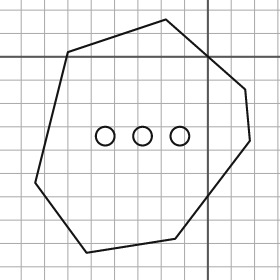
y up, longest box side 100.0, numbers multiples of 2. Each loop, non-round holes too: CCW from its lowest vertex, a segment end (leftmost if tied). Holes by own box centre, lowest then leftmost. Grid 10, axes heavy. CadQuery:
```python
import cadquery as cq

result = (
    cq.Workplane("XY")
    .moveTo(-52.0, -84.0)
    .lineTo(-14.0, -78.0)
    .lineTo(18.0, -36.0)
    .lineTo(16.0, -14.0)
    .lineTo(-18.0, 16.0)
    .lineTo(-60.0, 2.0)
    .lineTo(-74.0, -54.0)
    .close()
    .moveTo(-44.0, -34.0)
    .circle(4.0)
    .moveTo(-28.0, -34.0)
    .circle(4.0)
    .moveTo(-12.0, -34.0)
    .circle(4.0)
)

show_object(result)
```